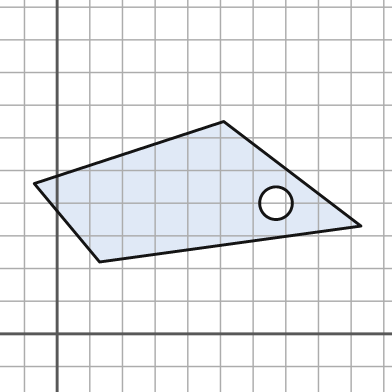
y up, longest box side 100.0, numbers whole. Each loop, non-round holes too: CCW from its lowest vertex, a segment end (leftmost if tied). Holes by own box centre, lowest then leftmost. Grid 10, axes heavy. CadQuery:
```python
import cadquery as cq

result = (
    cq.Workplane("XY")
    .moveTo(13.0, 22.0)
    .lineTo(93.0, 33.0)
    .lineTo(51.0, 65.0)
    .lineTo(-7.0, 46.0)
    .close()
    .moveTo(67.0, 40.0)
    .circle(5.0)
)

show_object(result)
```